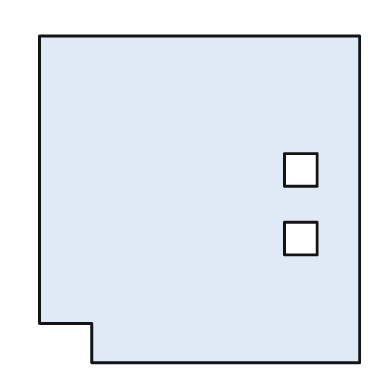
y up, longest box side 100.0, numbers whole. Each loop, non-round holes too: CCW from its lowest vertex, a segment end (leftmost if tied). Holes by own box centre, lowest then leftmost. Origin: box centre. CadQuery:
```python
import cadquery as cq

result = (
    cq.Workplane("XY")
    .moveTo(-33.0, -50.0)
    .lineTo(49.0, -50.0)
    .lineTo(49.0, 50.0)
    .lineTo(-49.0, 50.0)
    .lineTo(-49.0, -38.0)
    .lineTo(-33.0, -38.0)
    .close()
    .moveTo(26.0, -17.0)
    .lineTo(36.0, -17.0)
    .lineTo(36.0, -7.0)
    .lineTo(26.0, -7.0)
    .close()
    .moveTo(26.0, 4.0)
    .lineTo(36.0, 4.0)
    .lineTo(36.0, 14.0)
    .lineTo(26.0, 14.0)
    .close()
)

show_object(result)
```